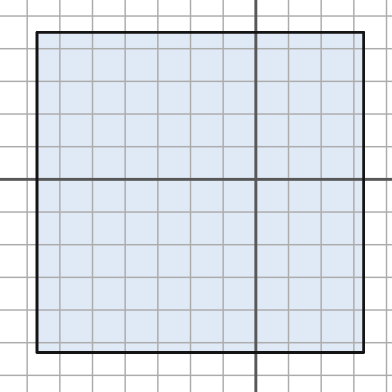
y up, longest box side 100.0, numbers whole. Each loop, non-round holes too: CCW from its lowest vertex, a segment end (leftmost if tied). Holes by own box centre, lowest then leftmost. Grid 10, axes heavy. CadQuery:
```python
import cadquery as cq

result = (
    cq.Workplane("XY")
    .moveTo(-67.0, -53.0)
    .lineTo(33.0, -53.0)
    .lineTo(33.0, 45.0)
    .lineTo(-67.0, 45.0)
    .close()
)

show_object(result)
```